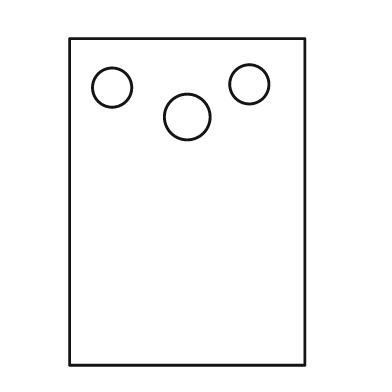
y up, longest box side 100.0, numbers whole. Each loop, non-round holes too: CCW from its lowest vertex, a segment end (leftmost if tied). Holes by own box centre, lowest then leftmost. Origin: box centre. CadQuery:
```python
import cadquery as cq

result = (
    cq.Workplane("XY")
    .moveTo(-36.0, -50.0)
    .lineTo(36.0, -50.0)
    .lineTo(36.0, 50.0)
    .lineTo(-36.0, 50.0)
    .close()
    .moveTo(0.0, 26.0)
    .circle(7.0)
    .moveTo(-23.0, 35.0)
    .circle(6.0)
    .moveTo(19.0, 36.0)
    .circle(6.0)
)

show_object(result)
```